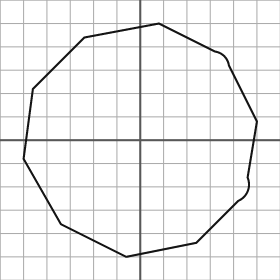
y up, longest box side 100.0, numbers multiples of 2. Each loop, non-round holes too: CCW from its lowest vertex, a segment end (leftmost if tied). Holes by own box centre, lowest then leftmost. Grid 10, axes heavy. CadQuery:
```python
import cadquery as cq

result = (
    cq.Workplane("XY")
    .moveTo(-6.0, -50.0)
    .lineTo(24.0, -44.0)
    .lineTo(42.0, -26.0)
    .threePointArc((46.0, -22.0), (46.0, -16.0))
    .lineTo(50.0, 8.0)
    .lineTo(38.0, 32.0)
    .threePointArc((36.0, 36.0), (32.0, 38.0))
    .lineTo(8.0, 50.0)
    .lineTo(-24.0, 44.0)
    .lineTo(-46.0, 22.0)
    .lineTo(-50.0, -8.0)
    .lineTo(-34.0, -36.0)
    .close()
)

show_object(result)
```